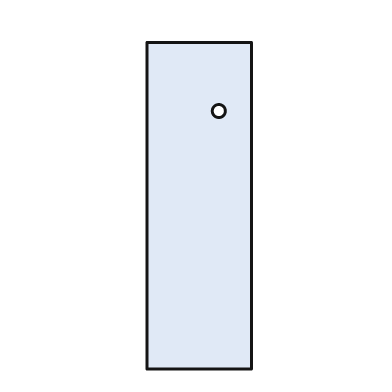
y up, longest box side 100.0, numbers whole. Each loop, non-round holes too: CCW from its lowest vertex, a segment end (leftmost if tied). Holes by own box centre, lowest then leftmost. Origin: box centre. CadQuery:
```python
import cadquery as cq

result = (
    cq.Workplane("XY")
    .moveTo(-16.0, -50.0)
    .lineTo(16.0, -50.0)
    .lineTo(16.0, 50.0)
    .lineTo(-16.0, 50.0)
    .close()
    .moveTo(6.0, 29.0)
    .circle(2.0)
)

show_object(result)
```